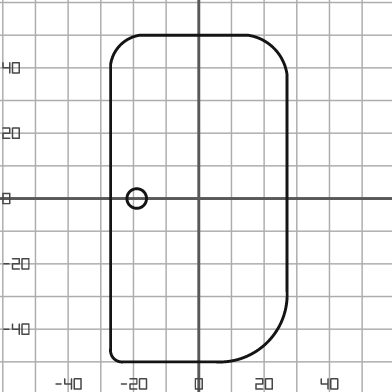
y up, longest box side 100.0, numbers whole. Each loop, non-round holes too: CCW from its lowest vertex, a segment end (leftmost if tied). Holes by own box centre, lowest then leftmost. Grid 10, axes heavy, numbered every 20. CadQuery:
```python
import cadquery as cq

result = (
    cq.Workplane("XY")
    .moveTo(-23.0, -50.0)
    .lineTo(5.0, -50.0)
    .threePointArc((21.0, -44.0), (27.0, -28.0))
    .lineTo(27.0, 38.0)
    .threePointArc((23.0, 46.0), (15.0, 50.0))
    .lineTo(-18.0, 50.0)
    .threePointArc((-24.0, 47.0), (-27.0, 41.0))
    .lineTo(-27.0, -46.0)
    .threePointArc((-26.0, -49.0), (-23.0, -50.0))
    .close()
    .moveTo(-19.0, 0.0)
    .circle(3.0)
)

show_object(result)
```